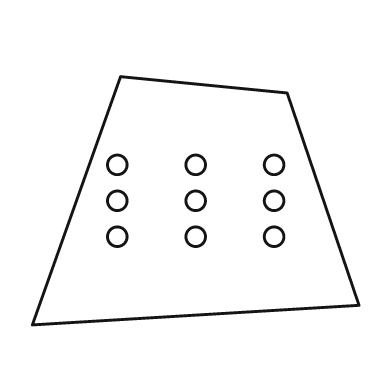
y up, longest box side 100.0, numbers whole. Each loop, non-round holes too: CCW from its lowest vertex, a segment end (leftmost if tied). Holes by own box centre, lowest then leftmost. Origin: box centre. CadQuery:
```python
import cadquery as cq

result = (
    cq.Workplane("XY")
    .moveTo(-50.0, -38.0)
    .lineTo(50.0, -32.0)
    .lineTo(28.0, 33.0)
    .lineTo(-23.0, 38.0)
    .close()
    .moveTo(-24.0, -11.0)
    .circle(3.0)
    .moveTo(0.0, -11.0)
    .circle(3.0)
    .moveTo(24.0, -11.0)
    .circle(3.0)
    .moveTo(-24.0, 0.0)
    .circle(3.0)
    .moveTo(0.0, 0.0)
    .circle(3.0)
    .moveTo(24.0, 0.0)
    .circle(3.0)
    .moveTo(-24.0, 11.0)
    .circle(3.0)
    .moveTo(0.0, 11.0)
    .circle(3.0)
    .moveTo(24.0, 11.0)
    .circle(3.0)
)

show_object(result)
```